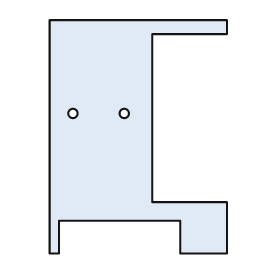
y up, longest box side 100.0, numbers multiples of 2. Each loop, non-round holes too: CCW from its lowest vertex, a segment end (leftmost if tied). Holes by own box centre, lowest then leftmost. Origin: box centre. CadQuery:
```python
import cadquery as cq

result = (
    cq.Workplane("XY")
    .moveTo(-38.0, -50.0)
    .lineTo(-34.0, -50.0)
    .lineTo(-34.0, -36.0)
    .lineTo(18.0, -36.0)
    .lineTo(18.0, -50.0)
    .lineTo(38.0, -50.0)
    .lineTo(38.0, -28.0)
    .lineTo(6.0, -28.0)
    .lineTo(6.0, 44.0)
    .lineTo(38.0, 44.0)
    .lineTo(38.0, 50.0)
    .lineTo(-38.0, 50.0)
    .close()
    .moveTo(-28.0, 10.0)
    .circle(2.0)
    .moveTo(-6.0, 10.0)
    .circle(2.0)
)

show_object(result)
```